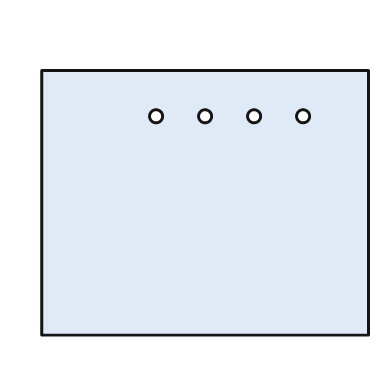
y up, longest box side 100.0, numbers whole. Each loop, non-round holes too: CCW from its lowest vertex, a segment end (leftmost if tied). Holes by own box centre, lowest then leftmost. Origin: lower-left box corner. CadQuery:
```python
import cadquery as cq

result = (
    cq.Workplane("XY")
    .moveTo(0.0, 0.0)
    .lineTo(100.0, 0.0)
    .lineTo(100.0, 81.0)
    .lineTo(0.0, 81.0)
    .close()
    .moveTo(35.0, 67.0)
    .circle(2.0)
    .moveTo(50.0, 67.0)
    .circle(2.0)
    .moveTo(65.0, 67.0)
    .circle(2.0)
    .moveTo(80.0, 67.0)
    .circle(2.0)
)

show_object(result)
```